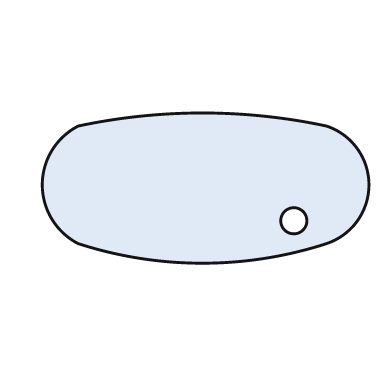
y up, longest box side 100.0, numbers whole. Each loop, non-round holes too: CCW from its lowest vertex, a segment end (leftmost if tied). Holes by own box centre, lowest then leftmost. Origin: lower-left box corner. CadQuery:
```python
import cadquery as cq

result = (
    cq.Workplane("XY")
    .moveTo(11.0, 6.0)
    .threePointArc((49.0, 0.0), (87.0, 6.0))
    .threePointArc((100.0, 24.0), (87.0, 42.0))
    .threePointArc((49.0, 46.0), (11.0, 42.0))
    .threePointArc((0.0, 24.0), (11.0, 6.0))
    .close()
    .moveTo(77.0, 13.0)
    .circle(4.0)
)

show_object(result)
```